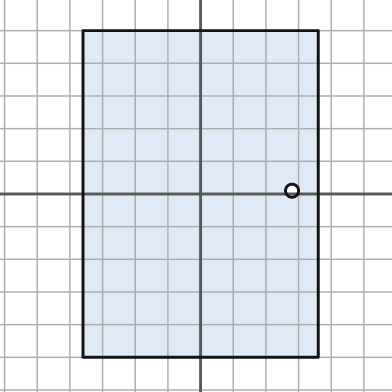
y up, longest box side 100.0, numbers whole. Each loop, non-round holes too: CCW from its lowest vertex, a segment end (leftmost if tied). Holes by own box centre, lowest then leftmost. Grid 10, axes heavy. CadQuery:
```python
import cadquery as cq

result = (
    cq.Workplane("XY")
    .moveTo(-36.0, -50.0)
    .lineTo(36.0, -50.0)
    .lineTo(36.0, 50.0)
    .lineTo(-36.0, 50.0)
    .close()
    .moveTo(28.0, 1.0)
    .circle(2.0)
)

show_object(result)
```